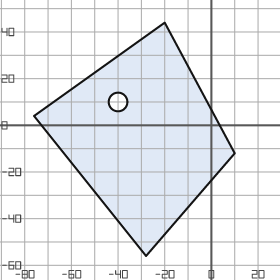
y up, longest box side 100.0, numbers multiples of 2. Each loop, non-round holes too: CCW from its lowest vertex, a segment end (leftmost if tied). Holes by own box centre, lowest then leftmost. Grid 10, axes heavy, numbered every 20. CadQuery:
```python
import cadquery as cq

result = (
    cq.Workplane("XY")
    .moveTo(-28.0, -56.0)
    .lineTo(10.0, -12.0)
    .lineTo(-20.0, 44.0)
    .lineTo(-76.0, 4.0)
    .close()
    .moveTo(-40.0, 10.0)
    .circle(4.0)
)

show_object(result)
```